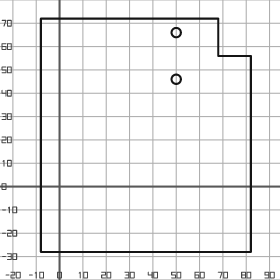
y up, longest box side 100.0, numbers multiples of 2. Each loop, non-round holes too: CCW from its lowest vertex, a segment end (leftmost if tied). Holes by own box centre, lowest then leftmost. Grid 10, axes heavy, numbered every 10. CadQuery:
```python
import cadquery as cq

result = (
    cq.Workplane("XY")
    .moveTo(-8.0, -28.0)
    .lineTo(82.0, -28.0)
    .lineTo(82.0, 56.0)
    .lineTo(68.0, 56.0)
    .lineTo(68.0, 72.0)
    .lineTo(-8.0, 72.0)
    .close()
    .moveTo(50.0, 46.0)
    .circle(2.0)
    .moveTo(50.0, 66.0)
    .circle(2.0)
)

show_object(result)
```